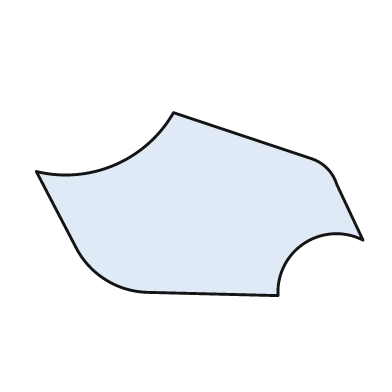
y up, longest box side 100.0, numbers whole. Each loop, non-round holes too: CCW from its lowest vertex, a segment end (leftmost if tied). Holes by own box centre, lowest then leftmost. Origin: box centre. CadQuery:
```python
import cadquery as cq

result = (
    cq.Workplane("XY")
    .moveTo(24.0, -28.0)
    .threePointArc((32.0, -12.0), (50.0, -11.0))
    .lineTo(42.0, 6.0)
    .threePointArc((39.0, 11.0), (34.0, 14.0))
    .lineTo(-8.0, 28.0)
    .threePointArc((-26.0, 12.0), (-50.0, 10.0))
    .lineTo(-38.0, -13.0)
    .threePointArc((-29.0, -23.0), (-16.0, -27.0))
    .close()
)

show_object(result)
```